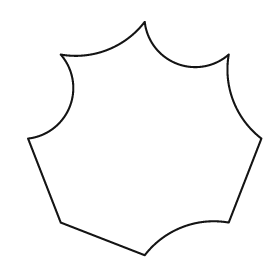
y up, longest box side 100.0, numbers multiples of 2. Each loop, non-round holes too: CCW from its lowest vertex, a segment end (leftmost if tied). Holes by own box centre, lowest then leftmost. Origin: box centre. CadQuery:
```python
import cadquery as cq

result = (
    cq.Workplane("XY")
    .moveTo(0.0, -50.0)
    .threePointArc((16.0, -38.0), (36.0, -36.0))
    .lineTo(50.0, 0.0)
    .threePointArc((38.0, 16.0), (36.0, 36.0))
    .threePointArc((14.0, 32.0), (0.0, 50.0))
    .threePointArc((-16.0, 38.0), (-36.0, 36.0))
    .threePointArc((-32.0, 14.0), (-50.0, 0.0))
    .lineTo(-36.0, -36.0)
    .close()
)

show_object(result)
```